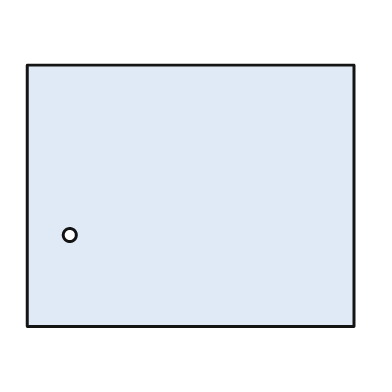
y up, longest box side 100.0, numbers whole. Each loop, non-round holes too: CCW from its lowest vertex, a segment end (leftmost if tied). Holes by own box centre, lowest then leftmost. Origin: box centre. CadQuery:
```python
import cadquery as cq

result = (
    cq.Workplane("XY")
    .moveTo(-50.0, -40.0)
    .lineTo(50.0, -40.0)
    .lineTo(50.0, 40.0)
    .lineTo(-50.0, 40.0)
    .close()
    .moveTo(-37.0, -12.0)
    .circle(2.0)
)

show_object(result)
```